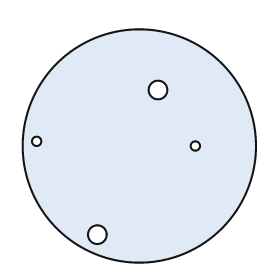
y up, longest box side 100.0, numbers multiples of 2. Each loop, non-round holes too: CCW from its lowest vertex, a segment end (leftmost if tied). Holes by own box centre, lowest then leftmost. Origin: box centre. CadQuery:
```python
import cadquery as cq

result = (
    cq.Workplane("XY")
    .moveTo(0.0, 0.0)
    .circle(50.0)
    .moveTo(-18.0, -38.0)
    .circle(4.0)
    .moveTo(24.0, 0.0)
    .circle(2.0)
    .moveTo(-44.0, 2.0)
    .circle(2.0)
    .moveTo(8.0, 24.0)
    .circle(4.0)
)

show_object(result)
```